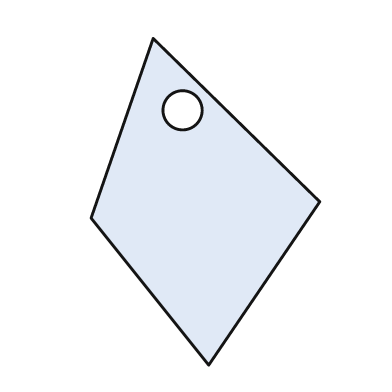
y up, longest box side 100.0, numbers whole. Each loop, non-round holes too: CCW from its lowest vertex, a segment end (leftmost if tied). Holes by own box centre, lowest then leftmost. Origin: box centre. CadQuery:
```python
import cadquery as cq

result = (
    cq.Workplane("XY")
    .moveTo(1.0, -50.0)
    .lineTo(35.0, 0.0)
    .lineTo(-16.0, 50.0)
    .lineTo(-35.0, -5.0)
    .close()
    .moveTo(-7.0, 28.0)
    .circle(6.0)
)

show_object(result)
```